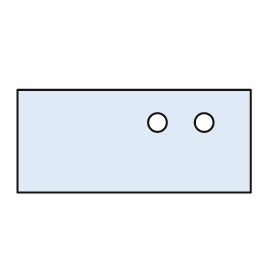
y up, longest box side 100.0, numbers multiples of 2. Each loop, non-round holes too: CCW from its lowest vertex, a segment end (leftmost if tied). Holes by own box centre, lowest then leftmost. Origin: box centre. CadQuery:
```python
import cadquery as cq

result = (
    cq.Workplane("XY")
    .moveTo(-50.0, -22.0)
    .lineTo(50.0, -22.0)
    .lineTo(50.0, 22.0)
    .lineTo(-50.0, 22.0)
    .close()
    .moveTo(10.0, 8.0)
    .circle(4.0)
    .moveTo(30.0, 8.0)
    .circle(4.0)
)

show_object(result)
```